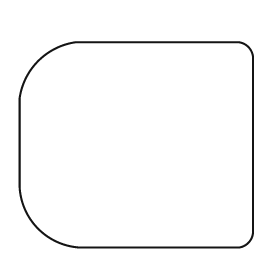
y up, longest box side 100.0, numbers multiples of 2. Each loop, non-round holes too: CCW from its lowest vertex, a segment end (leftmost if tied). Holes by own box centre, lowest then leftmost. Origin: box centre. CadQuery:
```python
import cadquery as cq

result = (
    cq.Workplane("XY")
    .moveTo(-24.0, -44.0)
    .lineTo(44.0, -44.0)
    .threePointArc((48.0, -42.0), (50.0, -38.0))
    .lineTo(50.0, 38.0)
    .threePointArc((48.0, 42.0), (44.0, 44.0))
    .lineTo(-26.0, 44.0)
    .threePointArc((-42.0, 36.0), (-50.0, 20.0))
    .lineTo(-50.0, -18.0)
    .threePointArc((-42.0, -36.0), (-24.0, -44.0))
    .close()
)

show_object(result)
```